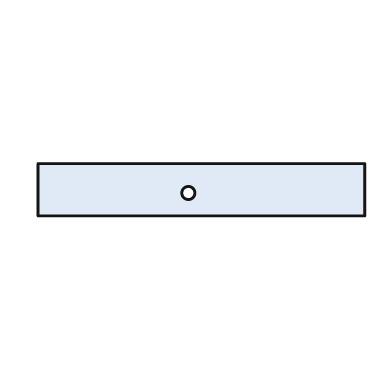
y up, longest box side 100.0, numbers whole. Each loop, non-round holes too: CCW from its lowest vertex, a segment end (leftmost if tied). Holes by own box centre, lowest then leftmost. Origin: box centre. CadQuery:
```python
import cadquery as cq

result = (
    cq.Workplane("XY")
    .moveTo(-50.0, -8.0)
    .lineTo(50.0, -8.0)
    .lineTo(50.0, 8.0)
    .lineTo(-50.0, 8.0)
    .close()
    .moveTo(-4.0, -1.0)
    .circle(2.0)
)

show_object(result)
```